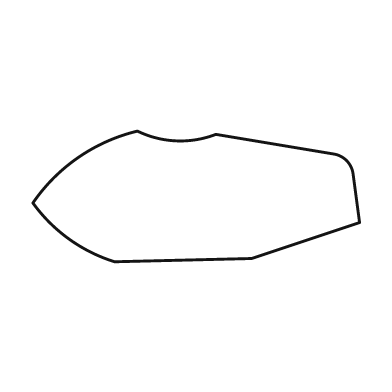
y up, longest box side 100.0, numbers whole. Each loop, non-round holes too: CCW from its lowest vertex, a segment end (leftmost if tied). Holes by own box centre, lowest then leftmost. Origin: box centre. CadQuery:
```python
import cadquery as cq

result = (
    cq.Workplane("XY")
    .moveTo(-25.0, -20.0)
    .lineTo(17.0, -19.0)
    .lineTo(50.0, -8.0)
    .lineTo(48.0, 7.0)
    .threePointArc((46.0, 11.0), (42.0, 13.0))
    .lineTo(6.0, 19.0)
    .threePointArc((-6.0, 17.0), (-18.0, 20.0))
    .threePointArc((-36.0, 12.0), (-50.0, -2.0))
    .threePointArc((-39.0, -13.0), (-25.0, -20.0))
    .close()
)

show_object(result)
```